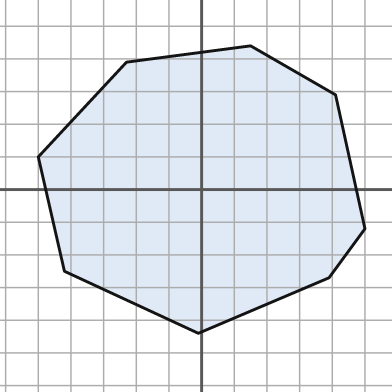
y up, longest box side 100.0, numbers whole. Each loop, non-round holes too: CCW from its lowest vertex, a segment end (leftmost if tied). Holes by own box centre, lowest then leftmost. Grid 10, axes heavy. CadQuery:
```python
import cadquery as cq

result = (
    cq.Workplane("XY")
    .moveTo(-1.0, -44.0)
    .lineTo(39.0, -27.0)
    .lineTo(50.0, -12.0)
    .lineTo(41.0, 29.0)
    .lineTo(15.0, 44.0)
    .lineTo(-23.0, 39.0)
    .lineTo(-50.0, 10.0)
    .lineTo(-42.0, -25.0)
    .close()
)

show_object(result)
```